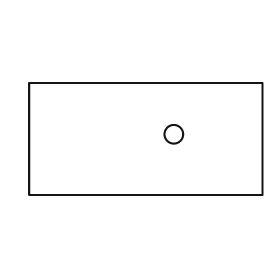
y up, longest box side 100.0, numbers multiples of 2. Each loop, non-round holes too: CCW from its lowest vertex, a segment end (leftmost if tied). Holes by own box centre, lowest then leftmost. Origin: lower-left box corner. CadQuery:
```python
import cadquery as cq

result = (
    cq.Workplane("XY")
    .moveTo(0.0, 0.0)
    .lineTo(100.0, 0.0)
    .lineTo(100.0, 48.0)
    .lineTo(0.0, 48.0)
    .close()
    .moveTo(62.0, 26.0)
    .circle(4.0)
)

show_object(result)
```